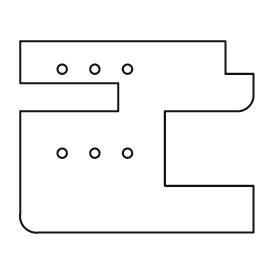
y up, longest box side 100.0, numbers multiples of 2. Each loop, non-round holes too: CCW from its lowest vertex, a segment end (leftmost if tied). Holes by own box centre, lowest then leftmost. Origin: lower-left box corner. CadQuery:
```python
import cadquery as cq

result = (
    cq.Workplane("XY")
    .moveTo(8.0, 0.0)
    .lineTo(100.0, 0.0)
    .lineTo(100.0, 20.0)
    .lineTo(62.0, 20.0)
    .lineTo(62.0, 52.0)
    .lineTo(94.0, 52.0)
    .threePointArc((98.0, 54.0), (100.0, 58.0))
    .lineTo(100.0, 68.0)
    .lineTo(88.0, 68.0)
    .lineTo(88.0, 82.0)
    .lineTo(0.0, 82.0)
    .lineTo(0.0, 64.0)
    .lineTo(42.0, 64.0)
    .lineTo(42.0, 52.0)
    .lineTo(0.0, 52.0)
    .lineTo(0.0, 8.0)
    .threePointArc((2.0, 2.0), (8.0, 0.0))
    .close()
    .moveTo(18.0, 34.0)
    .circle(2.0)
    .moveTo(32.0, 34.0)
    .circle(2.0)
    .moveTo(46.0, 34.0)
    .circle(2.0)
    .moveTo(18.0, 70.0)
    .circle(2.0)
    .moveTo(32.0, 70.0)
    .circle(2.0)
    .moveTo(46.0, 70.0)
    .circle(2.0)
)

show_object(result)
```